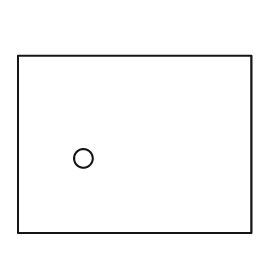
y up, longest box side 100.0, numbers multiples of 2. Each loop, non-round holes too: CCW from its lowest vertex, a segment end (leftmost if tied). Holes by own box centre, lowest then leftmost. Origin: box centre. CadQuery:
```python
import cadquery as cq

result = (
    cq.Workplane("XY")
    .moveTo(-50.0, -38.0)
    .lineTo(50.0, -38.0)
    .lineTo(50.0, 38.0)
    .lineTo(-50.0, 38.0)
    .close()
    .moveTo(-22.0, -6.0)
    .circle(4.0)
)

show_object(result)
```